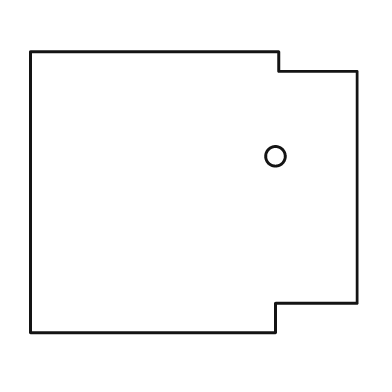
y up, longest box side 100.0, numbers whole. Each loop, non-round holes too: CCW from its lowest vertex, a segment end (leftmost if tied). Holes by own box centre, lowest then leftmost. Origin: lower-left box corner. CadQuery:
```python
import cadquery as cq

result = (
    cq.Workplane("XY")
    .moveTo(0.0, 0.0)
    .lineTo(75.0, 0.0)
    .lineTo(75.0, 9.0)
    .lineTo(100.0, 9.0)
    .lineTo(100.0, 80.0)
    .lineTo(76.0, 80.0)
    .lineTo(76.0, 86.0)
    .lineTo(0.0, 86.0)
    .close()
    .moveTo(75.0, 54.0)
    .circle(3.0)
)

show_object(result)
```